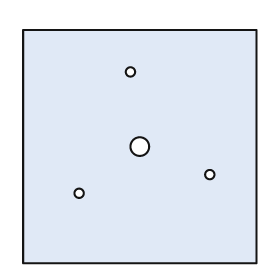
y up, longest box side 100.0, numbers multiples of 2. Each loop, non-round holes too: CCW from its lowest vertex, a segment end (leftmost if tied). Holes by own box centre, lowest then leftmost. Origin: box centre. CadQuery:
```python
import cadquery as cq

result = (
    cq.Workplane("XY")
    .moveTo(-50.0, -50.0)
    .lineTo(50.0, -50.0)
    .lineTo(50.0, 50.0)
    .lineTo(-50.0, 50.0)
    .close()
    .moveTo(-26.0, -20.0)
    .circle(2.0)
    .moveTo(30.0, -12.0)
    .circle(2.0)
    .moveTo(0.0, 0.0)
    .circle(4.0)
    .moveTo(-4.0, 32.0)
    .circle(2.0)
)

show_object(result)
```